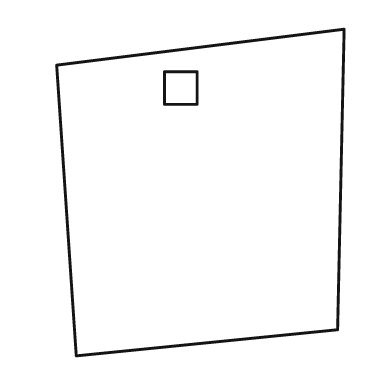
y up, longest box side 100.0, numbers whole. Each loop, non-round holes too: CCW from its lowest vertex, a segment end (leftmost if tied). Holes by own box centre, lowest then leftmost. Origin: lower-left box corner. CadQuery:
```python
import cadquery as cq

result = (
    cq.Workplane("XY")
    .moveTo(6.0, 0.0)
    .lineTo(86.0, 8.0)
    .lineTo(88.0, 100.0)
    .lineTo(0.0, 89.0)
    .close()
    .moveTo(33.0, 77.0)
    .lineTo(43.0, 77.0)
    .lineTo(43.0, 87.0)
    .lineTo(33.0, 87.0)
    .close()
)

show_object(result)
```